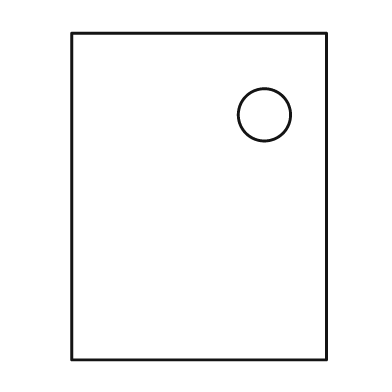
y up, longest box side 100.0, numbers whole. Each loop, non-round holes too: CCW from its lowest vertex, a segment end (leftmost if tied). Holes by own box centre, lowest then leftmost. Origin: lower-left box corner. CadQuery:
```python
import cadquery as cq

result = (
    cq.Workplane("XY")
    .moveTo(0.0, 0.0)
    .lineTo(78.0, 0.0)
    .lineTo(78.0, 100.0)
    .lineTo(0.0, 100.0)
    .close()
    .moveTo(59.0, 75.0)
    .circle(8.0)
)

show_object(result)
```